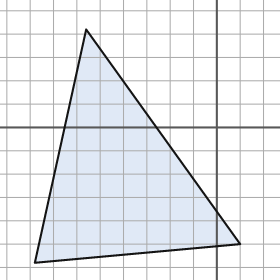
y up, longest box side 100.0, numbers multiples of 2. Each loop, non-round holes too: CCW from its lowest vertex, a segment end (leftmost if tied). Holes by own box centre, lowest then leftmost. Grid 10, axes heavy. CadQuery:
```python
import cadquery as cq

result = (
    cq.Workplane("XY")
    .moveTo(-78.0, -58.0)
    .lineTo(10.0, -50.0)
    .lineTo(-56.0, 42.0)
    .close()
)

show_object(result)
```